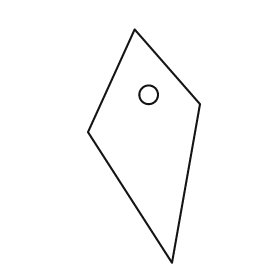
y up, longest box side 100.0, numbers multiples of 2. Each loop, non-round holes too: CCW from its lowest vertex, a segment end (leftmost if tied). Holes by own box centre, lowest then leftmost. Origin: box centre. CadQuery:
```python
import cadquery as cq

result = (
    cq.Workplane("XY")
    .moveTo(12.0, -50.0)
    .lineTo(24.0, 18.0)
    .lineTo(-4.0, 50.0)
    .lineTo(-24.0, 6.0)
    .close()
    .moveTo(2.0, 22.0)
    .circle(4.0)
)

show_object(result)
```